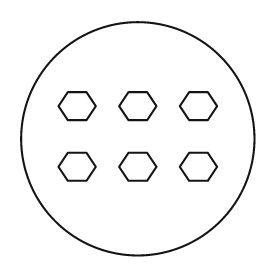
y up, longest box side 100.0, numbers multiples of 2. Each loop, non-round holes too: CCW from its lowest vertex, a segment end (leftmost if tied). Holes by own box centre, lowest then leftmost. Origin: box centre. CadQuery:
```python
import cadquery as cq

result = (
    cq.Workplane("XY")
    .moveTo(0.0, 0.0)
    .circle(50.0)
    .moveTo(-30.0, -18.0)
    .lineTo(-22.0, -18.0)
    .lineTo(-18.0, -12.0)
    .lineTo(-22.0, -6.0)
    .lineTo(-30.0, -6.0)
    .lineTo(-34.0, -12.0)
    .close()
    .moveTo(-4.0, -18.0)
    .lineTo(4.0, -18.0)
    .lineTo(8.0, -12.0)
    .lineTo(4.0, -6.0)
    .lineTo(-4.0, -6.0)
    .lineTo(-8.0, -12.0)
    .close()
    .moveTo(22.0, -18.0)
    .lineTo(30.0, -18.0)
    .lineTo(34.0, -12.0)
    .lineTo(30.0, -6.0)
    .lineTo(22.0, -6.0)
    .lineTo(18.0, -12.0)
    .close()
    .moveTo(-30.0, 8.0)
    .lineTo(-22.0, 8.0)
    .lineTo(-18.0, 14.0)
    .lineTo(-22.0, 20.0)
    .lineTo(-30.0, 20.0)
    .lineTo(-34.0, 14.0)
    .close()
    .moveTo(-4.0, 8.0)
    .lineTo(4.0, 8.0)
    .lineTo(8.0, 14.0)
    .lineTo(4.0, 20.0)
    .lineTo(-4.0, 20.0)
    .lineTo(-8.0, 14.0)
    .close()
    .moveTo(22.0, 8.0)
    .lineTo(30.0, 8.0)
    .lineTo(34.0, 14.0)
    .lineTo(30.0, 20.0)
    .lineTo(22.0, 20.0)
    .lineTo(18.0, 14.0)
    .close()
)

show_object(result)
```